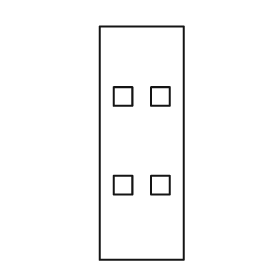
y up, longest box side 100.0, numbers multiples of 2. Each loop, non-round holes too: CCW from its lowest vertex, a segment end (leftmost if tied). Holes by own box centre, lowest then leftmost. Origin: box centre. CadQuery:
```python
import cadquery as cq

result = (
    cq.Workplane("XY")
    .moveTo(-18.0, -50.0)
    .lineTo(18.0, -50.0)
    .lineTo(18.0, 50.0)
    .lineTo(-18.0, 50.0)
    .close()
    .moveTo(-12.0, -22.0)
    .lineTo(-4.0, -22.0)
    .lineTo(-4.0, -14.0)
    .lineTo(-12.0, -14.0)
    .close()
    .moveTo(4.0, -22.0)
    .lineTo(12.0, -22.0)
    .lineTo(12.0, -14.0)
    .lineTo(4.0, -14.0)
    .close()
    .moveTo(-12.0, 16.0)
    .lineTo(-4.0, 16.0)
    .lineTo(-4.0, 24.0)
    .lineTo(-12.0, 24.0)
    .close()
    .moveTo(4.0, 16.0)
    .lineTo(12.0, 16.0)
    .lineTo(12.0, 24.0)
    .lineTo(4.0, 24.0)
    .close()
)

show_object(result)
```